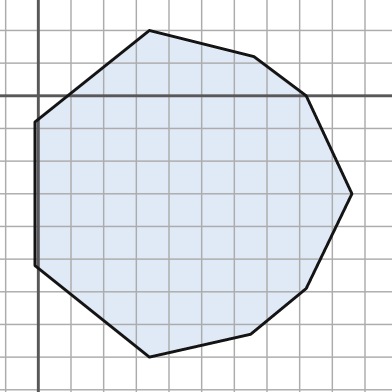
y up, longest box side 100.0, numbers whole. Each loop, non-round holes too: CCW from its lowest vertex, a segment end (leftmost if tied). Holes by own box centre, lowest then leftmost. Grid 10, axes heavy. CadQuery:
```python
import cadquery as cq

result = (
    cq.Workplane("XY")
    .moveTo(34.0, -80.0)
    .lineTo(65.0, -73.0)
    .lineTo(82.0, -59.0)
    .lineTo(96.0, -30.0)
    .lineTo(82.0, 0.0)
    .lineTo(66.0, 12.0)
    .lineTo(34.0, 20.0)
    .lineTo(-1.0, -8.0)
    .lineTo(-1.0, -52.0)
    .close()
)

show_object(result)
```